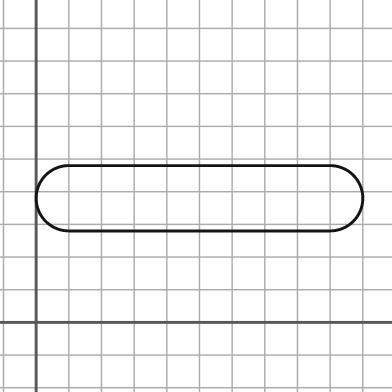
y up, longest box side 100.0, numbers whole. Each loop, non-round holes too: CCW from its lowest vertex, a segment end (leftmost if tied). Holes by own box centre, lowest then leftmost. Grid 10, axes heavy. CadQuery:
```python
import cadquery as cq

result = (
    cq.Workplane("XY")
    .moveTo(10.0, 28.0)
    .lineTo(90.0, 28.0)
    .threePointArc((100.0, 38.0), (90.0, 48.0))
    .lineTo(10.0, 48.0)
    .threePointArc((0.0, 38.0), (10.0, 28.0))
    .close()
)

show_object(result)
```